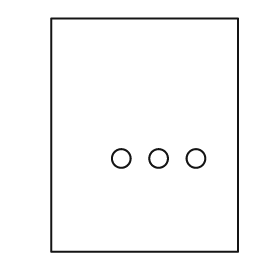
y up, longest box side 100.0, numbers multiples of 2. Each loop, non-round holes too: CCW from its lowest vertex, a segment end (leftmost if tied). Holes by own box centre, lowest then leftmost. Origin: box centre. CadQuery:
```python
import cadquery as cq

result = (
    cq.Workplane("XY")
    .moveTo(-40.0, -50.0)
    .lineTo(40.0, -50.0)
    .lineTo(40.0, 50.0)
    .lineTo(-40.0, 50.0)
    .close()
    .moveTo(-10.0, -10.0)
    .circle(4.0)
    .moveTo(6.0, -10.0)
    .circle(4.0)
    .moveTo(22.0, -10.0)
    .circle(4.0)
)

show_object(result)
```